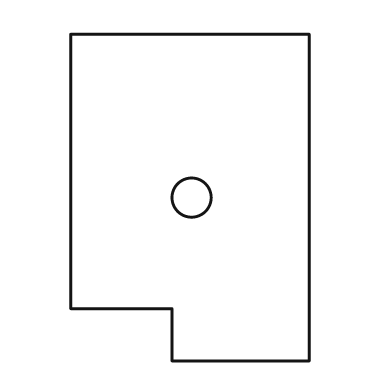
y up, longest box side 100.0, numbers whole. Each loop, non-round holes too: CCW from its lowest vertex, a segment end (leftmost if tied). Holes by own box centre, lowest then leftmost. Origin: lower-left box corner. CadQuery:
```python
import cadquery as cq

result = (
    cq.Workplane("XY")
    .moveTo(31.0, 0.0)
    .lineTo(73.0, 0.0)
    .lineTo(73.0, 100.0)
    .lineTo(0.0, 100.0)
    .lineTo(0.0, 16.0)
    .lineTo(31.0, 16.0)
    .close()
    .moveTo(37.0, 50.0)
    .circle(6.0)
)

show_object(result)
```